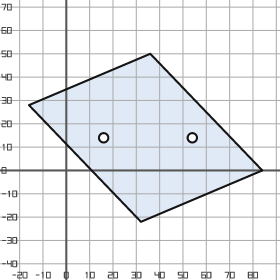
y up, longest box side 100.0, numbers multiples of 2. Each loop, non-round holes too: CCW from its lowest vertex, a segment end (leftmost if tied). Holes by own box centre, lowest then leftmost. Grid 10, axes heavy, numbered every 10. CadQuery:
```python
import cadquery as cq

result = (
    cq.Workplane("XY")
    .moveTo(32.0, -22.0)
    .lineTo(84.0, 0.0)
    .lineTo(36.0, 50.0)
    .lineTo(-16.0, 28.0)
    .close()
    .moveTo(16.0, 14.0)
    .circle(2.0)
    .moveTo(54.0, 14.0)
    .circle(2.0)
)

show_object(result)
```